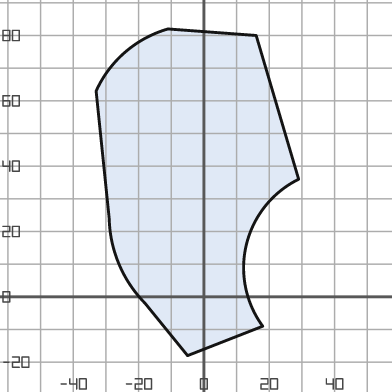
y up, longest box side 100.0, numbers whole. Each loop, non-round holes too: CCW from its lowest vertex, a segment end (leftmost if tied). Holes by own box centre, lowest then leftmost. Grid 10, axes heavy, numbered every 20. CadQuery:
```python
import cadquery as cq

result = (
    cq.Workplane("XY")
    .moveTo(-5.0, -18.0)
    .lineTo(18.0, -9.0)
    .threePointArc((13.0, 16.0), (29.0, 36.0))
    .lineTo(16.0, 80.0)
    .lineTo(-11.0, 82.0)
    .threePointArc((-24.0, 75.0), (-33.0, 63.0))
    .lineTo(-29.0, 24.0)
    .threePointArc((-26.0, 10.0), (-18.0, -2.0))
    .close()
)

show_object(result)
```